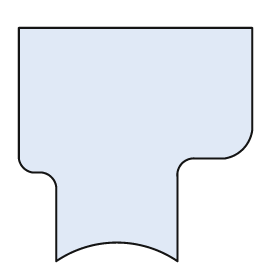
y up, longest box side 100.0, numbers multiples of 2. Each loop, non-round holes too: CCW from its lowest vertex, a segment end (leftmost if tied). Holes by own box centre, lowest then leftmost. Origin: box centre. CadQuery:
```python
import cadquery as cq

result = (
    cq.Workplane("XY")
    .moveTo(-34.0, -50.0)
    .threePointArc((-8.0, -42.0), (18.0, -50.0))
    .lineTo(18.0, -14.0)
    .threePointArc((20.0, -8.0), (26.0, -6.0))
    .lineTo(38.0, -6.0)
    .threePointArc((46.0, -2.0), (50.0, 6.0))
    .lineTo(50.0, 50.0)
    .lineTo(-50.0, 50.0)
    .lineTo(-50.0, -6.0)
    .threePointArc((-48.0, -10.0), (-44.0, -12.0))
    .lineTo(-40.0, -12.0)
    .threePointArc((-36.0, -14.0), (-34.0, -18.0))
    .close()
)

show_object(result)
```